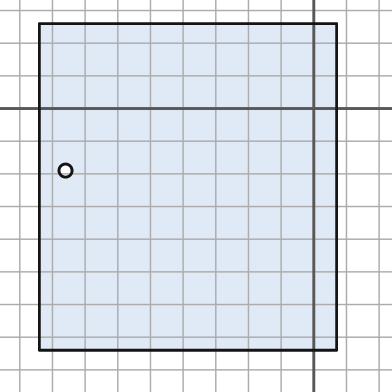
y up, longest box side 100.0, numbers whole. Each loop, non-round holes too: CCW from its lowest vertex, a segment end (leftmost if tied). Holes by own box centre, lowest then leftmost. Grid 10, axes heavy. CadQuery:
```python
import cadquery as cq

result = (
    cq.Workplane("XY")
    .moveTo(-84.0, -74.0)
    .lineTo(7.0, -74.0)
    .lineTo(7.0, 26.0)
    .lineTo(-84.0, 26.0)
    .close()
    .moveTo(-76.0, -19.0)
    .circle(2.0)
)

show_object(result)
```